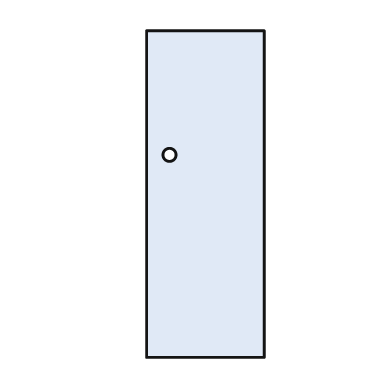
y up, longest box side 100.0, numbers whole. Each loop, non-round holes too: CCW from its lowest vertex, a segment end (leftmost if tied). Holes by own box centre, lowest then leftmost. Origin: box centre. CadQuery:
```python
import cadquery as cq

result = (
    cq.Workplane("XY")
    .moveTo(-18.0, -50.0)
    .lineTo(18.0, -50.0)
    .lineTo(18.0, 50.0)
    .lineTo(-18.0, 50.0)
    .close()
    .moveTo(-11.0, 12.0)
    .circle(2.0)
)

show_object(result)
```